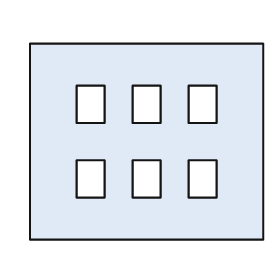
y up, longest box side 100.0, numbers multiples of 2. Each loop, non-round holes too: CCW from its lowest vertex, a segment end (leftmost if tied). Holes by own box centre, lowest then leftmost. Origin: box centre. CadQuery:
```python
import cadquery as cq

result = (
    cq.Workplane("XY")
    .moveTo(-50.0, -42.0)
    .lineTo(50.0, -42.0)
    .lineTo(50.0, 42.0)
    .lineTo(-50.0, 42.0)
    .close()
    .moveTo(-30.0, -24.0)
    .lineTo(-18.0, -24.0)
    .lineTo(-18.0, -8.0)
    .lineTo(-30.0, -8.0)
    .close()
    .moveTo(-6.0, -24.0)
    .lineTo(6.0, -24.0)
    .lineTo(6.0, -8.0)
    .lineTo(-6.0, -8.0)
    .close()
    .moveTo(18.0, -24.0)
    .lineTo(30.0, -24.0)
    .lineTo(30.0, -8.0)
    .lineTo(18.0, -8.0)
    .close()
    .moveTo(-30.0, 8.0)
    .lineTo(-18.0, 8.0)
    .lineTo(-18.0, 24.0)
    .lineTo(-30.0, 24.0)
    .close()
    .moveTo(-6.0, 8.0)
    .lineTo(6.0, 8.0)
    .lineTo(6.0, 24.0)
    .lineTo(-6.0, 24.0)
    .close()
    .moveTo(18.0, 8.0)
    .lineTo(30.0, 8.0)
    .lineTo(30.0, 24.0)
    .lineTo(18.0, 24.0)
    .close()
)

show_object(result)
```